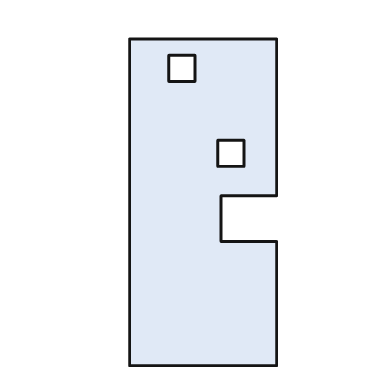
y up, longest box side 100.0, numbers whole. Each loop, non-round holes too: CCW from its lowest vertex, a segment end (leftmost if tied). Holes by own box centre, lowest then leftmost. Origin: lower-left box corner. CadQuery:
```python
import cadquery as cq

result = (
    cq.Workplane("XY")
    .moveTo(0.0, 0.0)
    .lineTo(45.0, 0.0)
    .lineTo(45.0, 38.0)
    .lineTo(28.0, 38.0)
    .lineTo(28.0, 52.0)
    .lineTo(45.0, 52.0)
    .lineTo(45.0, 100.0)
    .lineTo(0.0, 100.0)
    .close()
    .moveTo(27.0, 61.0)
    .lineTo(35.0, 61.0)
    .lineTo(35.0, 69.0)
    .lineTo(27.0, 69.0)
    .close()
    .moveTo(12.0, 87.0)
    .lineTo(20.0, 87.0)
    .lineTo(20.0, 95.0)
    .lineTo(12.0, 95.0)
    .close()
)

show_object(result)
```